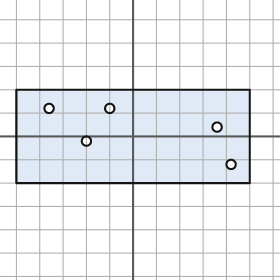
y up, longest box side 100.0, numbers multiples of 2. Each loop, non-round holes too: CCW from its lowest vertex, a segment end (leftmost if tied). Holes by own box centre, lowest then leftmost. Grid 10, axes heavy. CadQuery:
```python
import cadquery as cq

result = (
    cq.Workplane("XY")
    .moveTo(-50.0, -20.0)
    .lineTo(50.0, -20.0)
    .lineTo(50.0, 20.0)
    .lineTo(-50.0, 20.0)
    .close()
    .moveTo(42.0, -12.0)
    .circle(2.0)
    .moveTo(-20.0, -2.0)
    .circle(2.0)
    .moveTo(36.0, 4.0)
    .circle(2.0)
    .moveTo(-36.0, 12.0)
    .circle(2.0)
    .moveTo(-10.0, 12.0)
    .circle(2.0)
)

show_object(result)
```